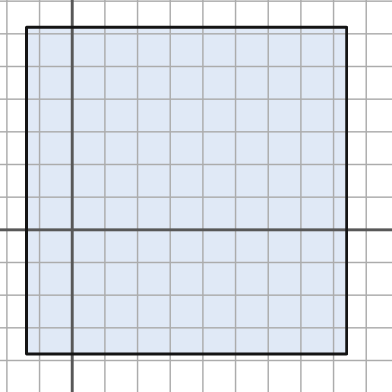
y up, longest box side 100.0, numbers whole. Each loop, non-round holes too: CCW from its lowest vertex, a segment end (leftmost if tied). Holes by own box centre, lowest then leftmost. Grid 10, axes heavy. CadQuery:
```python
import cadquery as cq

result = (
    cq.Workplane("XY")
    .moveTo(-14.0, -38.0)
    .lineTo(84.0, -38.0)
    .lineTo(84.0, 62.0)
    .lineTo(-14.0, 62.0)
    .close()
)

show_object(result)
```